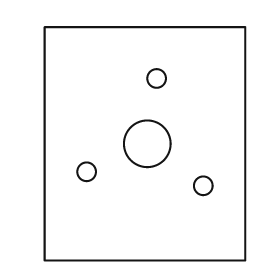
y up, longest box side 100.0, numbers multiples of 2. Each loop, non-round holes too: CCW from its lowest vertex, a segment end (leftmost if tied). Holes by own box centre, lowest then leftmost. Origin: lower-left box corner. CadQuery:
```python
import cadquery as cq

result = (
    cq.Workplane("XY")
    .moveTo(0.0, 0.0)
    .lineTo(86.0, 0.0)
    .lineTo(86.0, 100.0)
    .lineTo(0.0, 100.0)
    .close()
    .moveTo(68.0, 32.0)
    .circle(4.0)
    .moveTo(18.0, 38.0)
    .circle(4.0)
    .moveTo(44.0, 50.0)
    .circle(10.0)
    .moveTo(48.0, 78.0)
    .circle(4.0)
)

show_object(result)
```